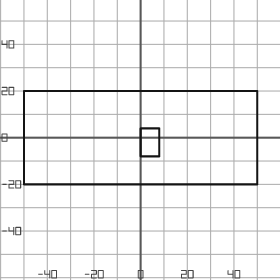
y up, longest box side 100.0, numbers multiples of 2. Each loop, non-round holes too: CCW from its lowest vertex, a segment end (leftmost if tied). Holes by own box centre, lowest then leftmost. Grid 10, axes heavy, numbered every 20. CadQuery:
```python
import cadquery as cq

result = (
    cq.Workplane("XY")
    .moveTo(-50.0, -20.0)
    .lineTo(50.0, -20.0)
    .lineTo(50.0, 20.0)
    .lineTo(-50.0, 20.0)
    .close()
    .moveTo(0.0, -8.0)
    .lineTo(8.0, -8.0)
    .lineTo(8.0, 4.0)
    .lineTo(0.0, 4.0)
    .close()
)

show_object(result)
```